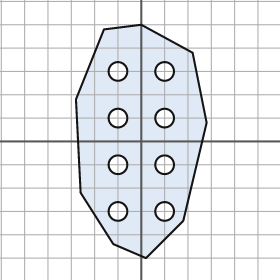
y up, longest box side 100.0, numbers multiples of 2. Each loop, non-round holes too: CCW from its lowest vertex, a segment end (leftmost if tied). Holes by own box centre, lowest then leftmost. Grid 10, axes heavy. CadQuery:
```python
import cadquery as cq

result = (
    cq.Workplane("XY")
    .moveTo(2.0, -50.0)
    .lineTo(18.0, -34.0)
    .lineTo(28.0, 8.0)
    .lineTo(22.0, 38.0)
    .lineTo(0.0, 50.0)
    .lineTo(-16.0, 48.0)
    .lineTo(-28.0, 18.0)
    .lineTo(-26.0, -22.0)
    .lineTo(-12.0, -44.0)
    .close()
    .moveTo(-10.0, -30.0)
    .circle(4.0)
    .moveTo(10.0, -30.0)
    .circle(4.0)
    .moveTo(-10.0, -10.0)
    .circle(4.0)
    .moveTo(10.0, -10.0)
    .circle(4.0)
    .moveTo(-10.0, 10.0)
    .circle(4.0)
    .moveTo(10.0, 10.0)
    .circle(4.0)
    .moveTo(-10.0, 30.0)
    .circle(4.0)
    .moveTo(10.0, 30.0)
    .circle(4.0)
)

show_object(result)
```